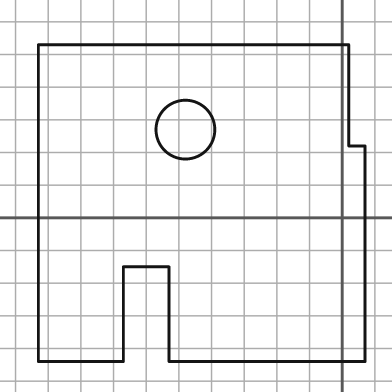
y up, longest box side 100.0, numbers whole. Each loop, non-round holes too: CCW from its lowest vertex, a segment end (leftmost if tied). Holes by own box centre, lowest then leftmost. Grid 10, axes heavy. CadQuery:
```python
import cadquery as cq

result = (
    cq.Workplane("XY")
    .moveTo(-93.0, -44.0)
    .lineTo(-67.0, -44.0)
    .lineTo(-67.0, -15.0)
    .lineTo(-53.0, -15.0)
    .lineTo(-53.0, -44.0)
    .lineTo(7.0, -44.0)
    .lineTo(7.0, 22.0)
    .lineTo(2.0, 22.0)
    .lineTo(2.0, 53.0)
    .lineTo(-93.0, 53.0)
    .close()
    .moveTo(-48.0, 27.0)
    .circle(9.0)
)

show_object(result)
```